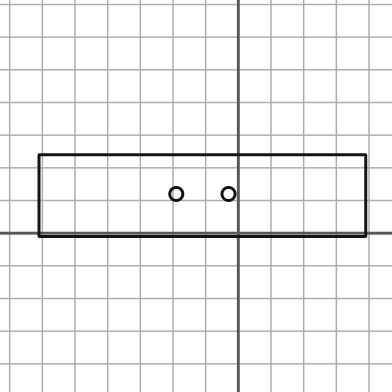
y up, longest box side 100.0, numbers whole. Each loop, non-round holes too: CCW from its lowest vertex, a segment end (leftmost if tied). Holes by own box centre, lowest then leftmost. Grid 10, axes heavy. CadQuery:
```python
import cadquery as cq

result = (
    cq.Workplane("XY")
    .moveTo(-61.0, -1.0)
    .lineTo(39.0, -1.0)
    .lineTo(39.0, 24.0)
    .lineTo(-61.0, 24.0)
    .close()
    .moveTo(-19.0, 12.0)
    .circle(2.0)
    .moveTo(-3.0, 12.0)
    .circle(2.0)
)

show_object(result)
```